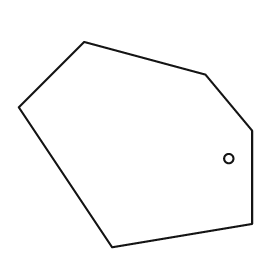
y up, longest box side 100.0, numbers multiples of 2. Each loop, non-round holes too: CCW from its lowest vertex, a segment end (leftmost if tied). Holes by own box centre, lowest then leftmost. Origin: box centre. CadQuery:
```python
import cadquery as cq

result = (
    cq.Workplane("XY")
    .moveTo(-10.0, -44.0)
    .lineTo(50.0, -34.0)
    .lineTo(50.0, 6.0)
    .lineTo(30.0, 30.0)
    .lineTo(-22.0, 44.0)
    .lineTo(-50.0, 16.0)
    .close()
    .moveTo(40.0, -6.0)
    .circle(2.0)
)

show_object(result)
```